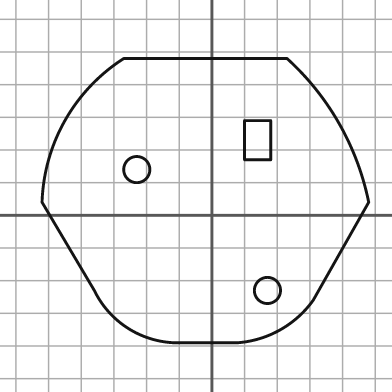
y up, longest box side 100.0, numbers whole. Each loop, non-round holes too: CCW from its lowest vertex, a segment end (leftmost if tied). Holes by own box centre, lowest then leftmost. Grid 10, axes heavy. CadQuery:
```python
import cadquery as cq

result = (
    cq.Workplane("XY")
    .moveTo(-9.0, -39.0)
    .lineTo(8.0, -39.0)
    .threePointArc((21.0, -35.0), (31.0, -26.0))
    .lineTo(48.0, 4.0)
    .threePointArc((39.0, 28.0), (23.0, 48.0))
    .lineTo(-27.0, 48.0)
    .threePointArc((-45.0, 29.0), (-52.0, 4.0))
    .lineTo(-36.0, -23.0)
    .threePointArc((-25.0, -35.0), (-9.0, -39.0))
    .close()
    .moveTo(17.0, -23.0)
    .circle(4.0)
    .moveTo(-23.0, 14.0)
    .circle(4.0)
    .moveTo(10.0, 17.0)
    .lineTo(18.0, 17.0)
    .lineTo(18.0, 29.0)
    .lineTo(10.0, 29.0)
    .close()
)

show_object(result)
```